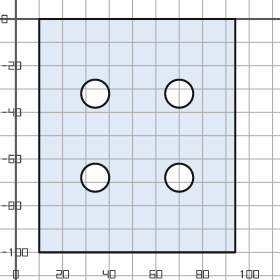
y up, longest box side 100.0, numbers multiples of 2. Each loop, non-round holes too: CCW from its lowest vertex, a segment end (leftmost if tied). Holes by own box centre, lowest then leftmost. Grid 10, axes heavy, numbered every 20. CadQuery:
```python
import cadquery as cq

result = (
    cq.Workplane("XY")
    .moveTo(10.0, -100.0)
    .lineTo(94.0, -100.0)
    .lineTo(94.0, 0.0)
    .lineTo(10.0, 0.0)
    .close()
    .moveTo(34.0, -68.0)
    .circle(6.0)
    .moveTo(70.0, -68.0)
    .circle(6.0)
    .moveTo(34.0, -32.0)
    .circle(6.0)
    .moveTo(70.0, -32.0)
    .circle(6.0)
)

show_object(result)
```